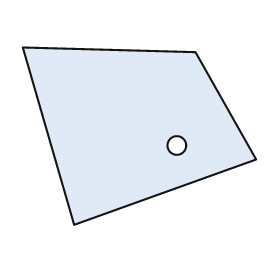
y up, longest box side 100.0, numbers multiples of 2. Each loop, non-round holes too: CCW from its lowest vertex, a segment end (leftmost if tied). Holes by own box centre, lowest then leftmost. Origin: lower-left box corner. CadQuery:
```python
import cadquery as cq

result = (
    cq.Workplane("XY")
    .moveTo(22.0, 0.0)
    .lineTo(100.0, 28.0)
    .lineTo(74.0, 74.0)
    .lineTo(0.0, 76.0)
    .close()
    .moveTo(66.0, 34.0)
    .circle(4.0)
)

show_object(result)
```